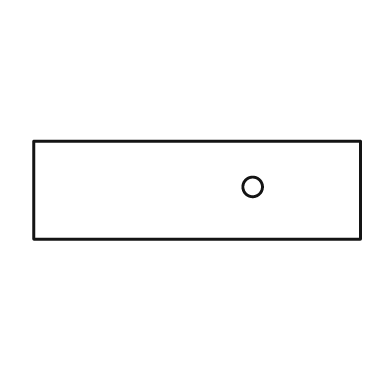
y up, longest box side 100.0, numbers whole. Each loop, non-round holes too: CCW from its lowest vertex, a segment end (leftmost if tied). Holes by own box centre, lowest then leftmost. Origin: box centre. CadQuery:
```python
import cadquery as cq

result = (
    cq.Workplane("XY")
    .moveTo(-50.0, -15.0)
    .lineTo(50.0, -15.0)
    .lineTo(50.0, 15.0)
    .lineTo(-50.0, 15.0)
    .close()
    .moveTo(17.0, 1.0)
    .circle(3.0)
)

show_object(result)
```